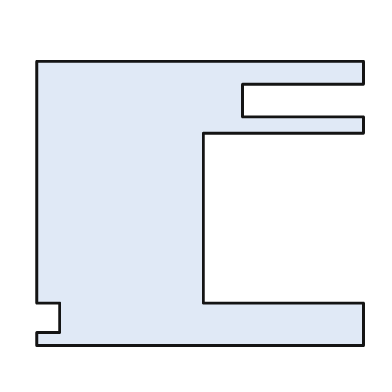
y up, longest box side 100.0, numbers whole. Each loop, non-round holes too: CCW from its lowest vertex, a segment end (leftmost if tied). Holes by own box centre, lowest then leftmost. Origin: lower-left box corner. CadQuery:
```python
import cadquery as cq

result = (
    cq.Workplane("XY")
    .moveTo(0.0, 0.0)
    .lineTo(100.0, 0.0)
    .lineTo(100.0, 13.0)
    .lineTo(51.0, 13.0)
    .lineTo(51.0, 65.0)
    .lineTo(100.0, 65.0)
    .lineTo(100.0, 70.0)
    .lineTo(63.0, 70.0)
    .lineTo(63.0, 80.0)
    .lineTo(100.0, 80.0)
    .lineTo(100.0, 87.0)
    .lineTo(0.0, 87.0)
    .lineTo(0.0, 13.0)
    .lineTo(7.0, 13.0)
    .lineTo(7.0, 4.0)
    .lineTo(0.0, 4.0)
    .close()
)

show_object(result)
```